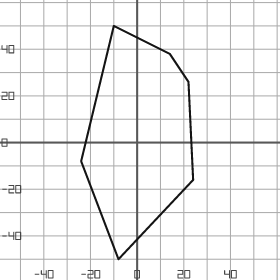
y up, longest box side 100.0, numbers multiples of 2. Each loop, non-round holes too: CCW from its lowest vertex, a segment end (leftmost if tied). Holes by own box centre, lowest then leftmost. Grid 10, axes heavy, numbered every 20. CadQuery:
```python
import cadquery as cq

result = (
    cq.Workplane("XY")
    .moveTo(-8.0, -50.0)
    .lineTo(24.0, -16.0)
    .lineTo(22.0, 26.0)
    .lineTo(14.0, 38.0)
    .lineTo(-10.0, 50.0)
    .lineTo(-24.0, -8.0)
    .close()
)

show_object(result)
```